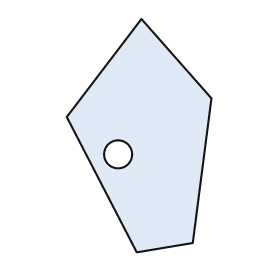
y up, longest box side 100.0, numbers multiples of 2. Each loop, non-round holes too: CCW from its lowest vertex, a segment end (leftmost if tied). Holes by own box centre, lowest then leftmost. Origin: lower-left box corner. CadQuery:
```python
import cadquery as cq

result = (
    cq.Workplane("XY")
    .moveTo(30.0, 0.0)
    .lineTo(54.0, 4.0)
    .lineTo(62.0, 66.0)
    .lineTo(32.0, 100.0)
    .lineTo(0.0, 58.0)
    .close()
    .moveTo(22.0, 42.0)
    .circle(6.0)
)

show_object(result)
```